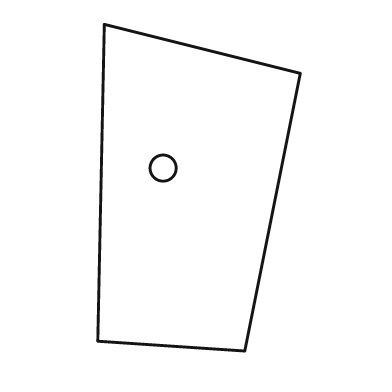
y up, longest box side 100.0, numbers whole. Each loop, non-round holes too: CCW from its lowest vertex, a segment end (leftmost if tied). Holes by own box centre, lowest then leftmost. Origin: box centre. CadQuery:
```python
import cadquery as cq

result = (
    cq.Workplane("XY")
    .moveTo(14.0, -50.0)
    .lineTo(31.0, 35.0)
    .lineTo(-29.0, 50.0)
    .lineTo(-31.0, -47.0)
    .close()
    .moveTo(-11.0, 6.0)
    .circle(4.0)
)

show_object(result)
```